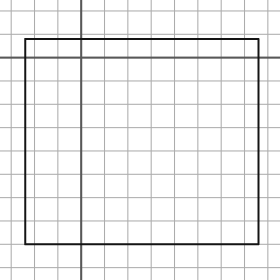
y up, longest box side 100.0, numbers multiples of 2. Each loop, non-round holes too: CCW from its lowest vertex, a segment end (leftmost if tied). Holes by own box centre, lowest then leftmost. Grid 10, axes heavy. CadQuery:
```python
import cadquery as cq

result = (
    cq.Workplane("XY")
    .moveTo(-24.0, -80.0)
    .lineTo(76.0, -80.0)
    .lineTo(76.0, 8.0)
    .lineTo(-24.0, 8.0)
    .close()
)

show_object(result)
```